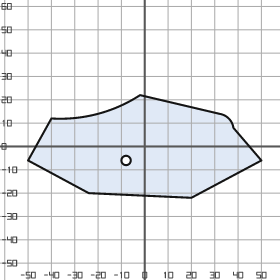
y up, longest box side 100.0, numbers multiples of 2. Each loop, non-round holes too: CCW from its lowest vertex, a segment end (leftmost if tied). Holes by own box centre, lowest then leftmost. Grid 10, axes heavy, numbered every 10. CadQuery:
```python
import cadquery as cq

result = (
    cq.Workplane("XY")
    .moveTo(20.0, -22.0)
    .lineTo(50.0, -6.0)
    .lineTo(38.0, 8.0)
    .threePointArc((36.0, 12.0), (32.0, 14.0))
    .lineTo(-2.0, 22.0)
    .threePointArc((-20.0, 14.0), (-40.0, 12.0))
    .lineTo(-50.0, -6.0)
    .lineTo(-24.0, -20.0)
    .close()
    .moveTo(-8.0, -6.0)
    .circle(2.0)
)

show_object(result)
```